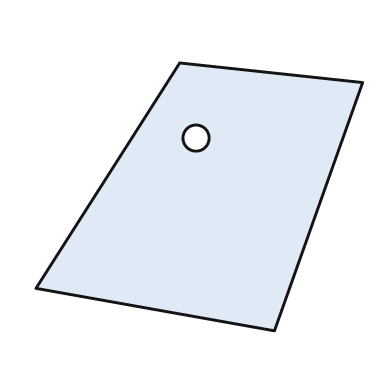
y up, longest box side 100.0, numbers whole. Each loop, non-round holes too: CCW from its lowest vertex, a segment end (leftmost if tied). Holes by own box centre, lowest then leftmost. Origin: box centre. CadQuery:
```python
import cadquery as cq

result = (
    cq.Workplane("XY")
    .moveTo(23.0, -41.0)
    .lineTo(50.0, 35.0)
    .lineTo(-6.0, 41.0)
    .lineTo(-50.0, -28.0)
    .close()
    .moveTo(-1.0, 18.0)
    .circle(4.0)
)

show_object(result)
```